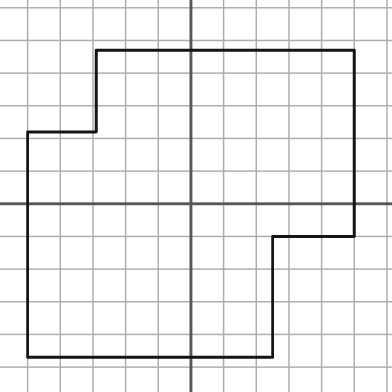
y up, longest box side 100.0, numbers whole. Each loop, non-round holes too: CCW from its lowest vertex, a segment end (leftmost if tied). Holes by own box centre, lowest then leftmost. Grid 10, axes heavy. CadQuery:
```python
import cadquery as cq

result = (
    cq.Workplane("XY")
    .moveTo(-50.0, -47.0)
    .lineTo(25.0, -47.0)
    .lineTo(25.0, -10.0)
    .lineTo(50.0, -10.0)
    .lineTo(50.0, 47.0)
    .lineTo(-29.0, 47.0)
    .lineTo(-29.0, 22.0)
    .lineTo(-50.0, 22.0)
    .close()
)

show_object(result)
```